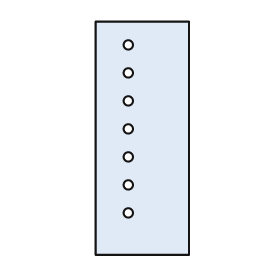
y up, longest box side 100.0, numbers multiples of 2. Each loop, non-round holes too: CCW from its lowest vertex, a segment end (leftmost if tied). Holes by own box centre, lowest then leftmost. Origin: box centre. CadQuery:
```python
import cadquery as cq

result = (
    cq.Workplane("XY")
    .moveTo(-20.0, -50.0)
    .lineTo(20.0, -50.0)
    .lineTo(20.0, 50.0)
    .lineTo(-20.0, 50.0)
    .close()
    .moveTo(-6.0, -32.0)
    .circle(2.0)
    .moveTo(-6.0, -20.0)
    .circle(2.0)
    .moveTo(-6.0, -8.0)
    .circle(2.0)
    .moveTo(-6.0, 4.0)
    .circle(2.0)
    .moveTo(-6.0, 16.0)
    .circle(2.0)
    .moveTo(-6.0, 28.0)
    .circle(2.0)
    .moveTo(-6.0, 40.0)
    .circle(2.0)
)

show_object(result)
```